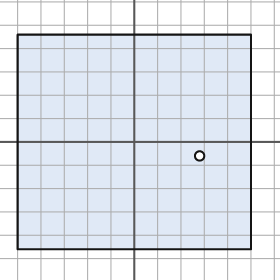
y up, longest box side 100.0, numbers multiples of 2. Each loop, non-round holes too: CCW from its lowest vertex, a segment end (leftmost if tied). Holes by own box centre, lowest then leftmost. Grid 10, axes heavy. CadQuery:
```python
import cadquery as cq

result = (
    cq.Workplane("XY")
    .moveTo(-50.0, -46.0)
    .lineTo(50.0, -46.0)
    .lineTo(50.0, 46.0)
    .lineTo(-50.0, 46.0)
    .close()
    .moveTo(28.0, -6.0)
    .circle(2.0)
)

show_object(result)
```